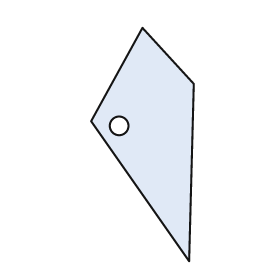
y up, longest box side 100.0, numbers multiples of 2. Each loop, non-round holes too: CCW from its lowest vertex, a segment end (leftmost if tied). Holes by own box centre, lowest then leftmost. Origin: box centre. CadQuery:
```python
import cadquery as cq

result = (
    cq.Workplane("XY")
    .moveTo(20.0, -50.0)
    .lineTo(22.0, 26.0)
    .lineTo(0.0, 50.0)
    .lineTo(-22.0, 10.0)
    .close()
    .moveTo(-10.0, 8.0)
    .circle(4.0)
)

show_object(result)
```